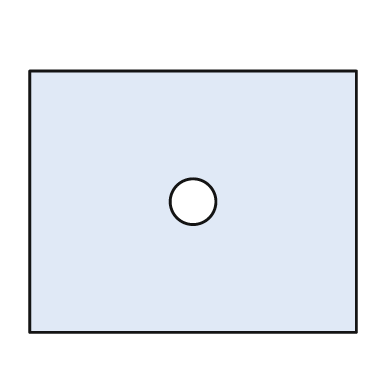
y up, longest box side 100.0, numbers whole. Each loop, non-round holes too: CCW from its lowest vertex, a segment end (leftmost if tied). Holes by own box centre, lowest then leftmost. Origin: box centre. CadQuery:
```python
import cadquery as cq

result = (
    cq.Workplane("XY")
    .moveTo(-50.0, -40.0)
    .lineTo(50.0, -40.0)
    .lineTo(50.0, 40.0)
    .lineTo(-50.0, 40.0)
    .close()
    .moveTo(0.0, 0.0)
    .circle(7.0)
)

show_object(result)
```